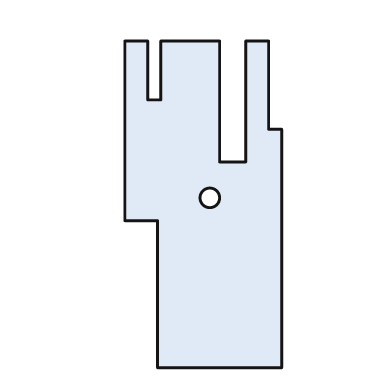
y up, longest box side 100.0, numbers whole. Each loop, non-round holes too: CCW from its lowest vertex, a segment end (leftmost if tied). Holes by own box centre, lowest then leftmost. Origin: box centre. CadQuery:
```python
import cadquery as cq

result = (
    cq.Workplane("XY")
    .moveTo(-14.0, -50.0)
    .lineTo(24.0, -50.0)
    .lineTo(24.0, 23.0)
    .lineTo(20.0, 23.0)
    .lineTo(20.0, 50.0)
    .lineTo(13.0, 50.0)
    .lineTo(13.0, 13.0)
    .lineTo(5.0, 13.0)
    .lineTo(5.0, 50.0)
    .lineTo(-13.0, 50.0)
    .lineTo(-13.0, 32.0)
    .lineTo(-17.0, 32.0)
    .lineTo(-17.0, 50.0)
    .lineTo(-24.0, 50.0)
    .lineTo(-24.0, -5.0)
    .lineTo(-14.0, -5.0)
    .close()
    .moveTo(2.0, 2.0)
    .circle(3.0)
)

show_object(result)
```